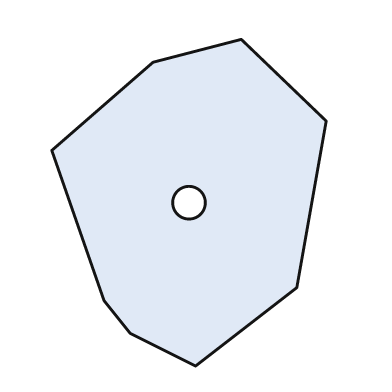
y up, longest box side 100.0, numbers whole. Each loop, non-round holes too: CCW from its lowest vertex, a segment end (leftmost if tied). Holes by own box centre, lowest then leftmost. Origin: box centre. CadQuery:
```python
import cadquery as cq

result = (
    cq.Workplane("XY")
    .moveTo(2.0, -50.0)
    .lineTo(33.0, -26.0)
    .lineTo(42.0, 25.0)
    .lineTo(16.0, 50.0)
    .lineTo(-11.0, 43.0)
    .lineTo(-42.0, 16.0)
    .lineTo(-26.0, -30.0)
    .lineTo(-18.0, -40.0)
    .close()
    .moveTo(0.0, 0.0)
    .circle(5.0)
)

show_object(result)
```